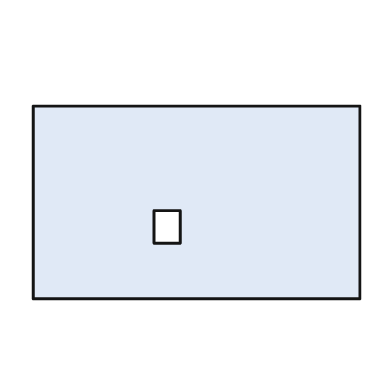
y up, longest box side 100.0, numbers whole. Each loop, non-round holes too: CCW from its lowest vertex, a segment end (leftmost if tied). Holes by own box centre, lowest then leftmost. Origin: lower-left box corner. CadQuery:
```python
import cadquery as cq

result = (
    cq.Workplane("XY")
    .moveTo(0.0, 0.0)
    .lineTo(100.0, 0.0)
    .lineTo(100.0, 59.0)
    .lineTo(0.0, 59.0)
    .close()
    .moveTo(37.0, 17.0)
    .lineTo(45.0, 17.0)
    .lineTo(45.0, 27.0)
    .lineTo(37.0, 27.0)
    .close()
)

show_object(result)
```